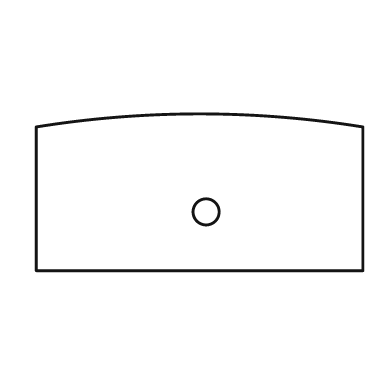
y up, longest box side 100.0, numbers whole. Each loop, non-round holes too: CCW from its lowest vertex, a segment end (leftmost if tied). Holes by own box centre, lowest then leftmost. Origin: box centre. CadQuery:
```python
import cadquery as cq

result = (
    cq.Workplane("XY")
    .moveTo(-50.0, -24.0)
    .lineTo(50.0, -24.0)
    .lineTo(50.0, 20.0)
    .threePointArc((0.0, 24.0), (-50.0, 20.0))
    .close()
    .moveTo(2.0, -6.0)
    .circle(4.0)
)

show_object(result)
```